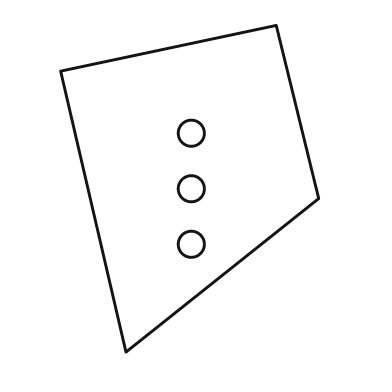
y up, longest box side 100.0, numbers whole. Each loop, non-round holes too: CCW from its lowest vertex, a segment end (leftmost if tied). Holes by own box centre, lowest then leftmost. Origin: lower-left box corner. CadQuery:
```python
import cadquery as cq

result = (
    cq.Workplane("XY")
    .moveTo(20.0, 0.0)
    .lineTo(79.0, 47.0)
    .lineTo(66.0, 100.0)
    .lineTo(0.0, 86.0)
    .close()
    .moveTo(40.0, 33.0)
    .circle(4.0)
    .moveTo(40.0, 50.0)
    .circle(4.0)
    .moveTo(40.0, 67.0)
    .circle(4.0)
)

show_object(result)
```